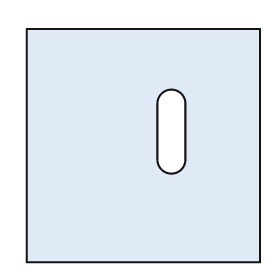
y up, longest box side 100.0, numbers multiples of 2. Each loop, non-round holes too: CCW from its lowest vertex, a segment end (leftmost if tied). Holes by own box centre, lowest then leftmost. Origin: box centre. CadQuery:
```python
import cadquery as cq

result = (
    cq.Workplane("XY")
    .moveTo(-50.0, -50.0)
    .lineTo(50.0, -50.0)
    .lineTo(50.0, 50.0)
    .lineTo(-50.0, 50.0)
    .close()
    .moveTo(6.0, -6.0)
    .threePointArc((12.0, -12.0), (18.0, -6.0))
    .lineTo(18.0, 18.0)
    .threePointArc((12.0, 24.0), (6.0, 18.0))
    .close()
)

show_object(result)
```